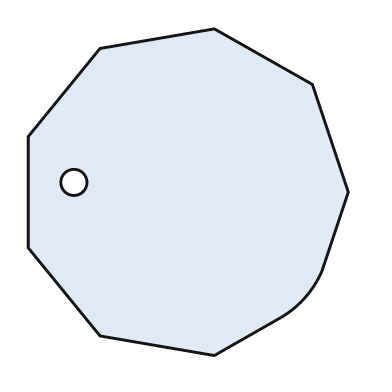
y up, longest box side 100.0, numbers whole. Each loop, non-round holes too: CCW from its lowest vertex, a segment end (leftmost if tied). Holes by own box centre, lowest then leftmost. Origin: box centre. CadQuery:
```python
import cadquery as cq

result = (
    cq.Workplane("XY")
    .moveTo(8.0, -50.0)
    .lineTo(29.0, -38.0)
    .threePointArc((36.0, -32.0), (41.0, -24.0))
    .lineTo(49.0, 0.0)
    .lineTo(38.0, 33.0)
    .lineTo(8.0, 50.0)
    .lineTo(-27.0, 44.0)
    .lineTo(-49.0, 17.0)
    .lineTo(-49.0, -17.0)
    .lineTo(-27.0, -44.0)
    .close()
    .moveTo(-35.0, 3.0)
    .circle(4.0)
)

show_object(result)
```